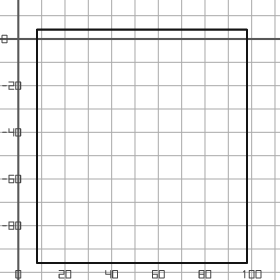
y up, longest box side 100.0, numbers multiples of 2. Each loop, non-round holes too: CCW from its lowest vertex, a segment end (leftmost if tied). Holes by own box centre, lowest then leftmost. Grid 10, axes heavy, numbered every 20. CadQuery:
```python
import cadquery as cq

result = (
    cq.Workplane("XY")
    .moveTo(8.0, -96.0)
    .lineTo(98.0, -96.0)
    .lineTo(98.0, 4.0)
    .lineTo(8.0, 4.0)
    .close()
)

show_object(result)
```